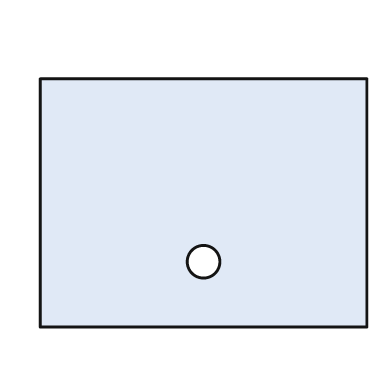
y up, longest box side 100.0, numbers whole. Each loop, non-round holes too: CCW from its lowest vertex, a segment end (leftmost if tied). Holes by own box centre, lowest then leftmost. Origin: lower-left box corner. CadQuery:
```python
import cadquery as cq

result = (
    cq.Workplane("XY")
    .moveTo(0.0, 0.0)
    .lineTo(100.0, 0.0)
    .lineTo(100.0, 76.0)
    .lineTo(0.0, 76.0)
    .close()
    .moveTo(50.0, 20.0)
    .circle(5.0)
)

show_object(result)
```